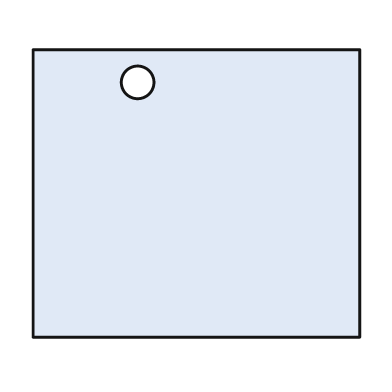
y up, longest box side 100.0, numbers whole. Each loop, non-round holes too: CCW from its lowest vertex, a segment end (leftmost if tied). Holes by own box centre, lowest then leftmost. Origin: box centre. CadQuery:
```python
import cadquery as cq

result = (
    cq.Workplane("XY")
    .moveTo(-50.0, -44.0)
    .lineTo(50.0, -44.0)
    .lineTo(50.0, 44.0)
    .lineTo(-50.0, 44.0)
    .close()
    .moveTo(-18.0, 34.0)
    .circle(5.0)
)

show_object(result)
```